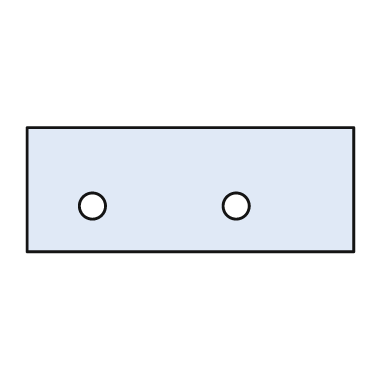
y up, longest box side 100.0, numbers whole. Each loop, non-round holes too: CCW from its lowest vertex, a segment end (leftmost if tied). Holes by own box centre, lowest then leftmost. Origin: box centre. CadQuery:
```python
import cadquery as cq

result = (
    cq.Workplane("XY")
    .moveTo(-50.0, -19.0)
    .lineTo(50.0, -19.0)
    .lineTo(50.0, 19.0)
    .lineTo(-50.0, 19.0)
    .close()
    .moveTo(-30.0, -5.0)
    .circle(4.0)
    .moveTo(14.0, -5.0)
    .circle(4.0)
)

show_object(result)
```